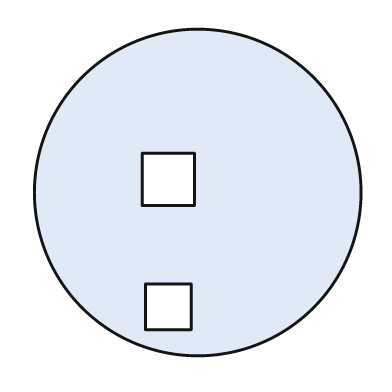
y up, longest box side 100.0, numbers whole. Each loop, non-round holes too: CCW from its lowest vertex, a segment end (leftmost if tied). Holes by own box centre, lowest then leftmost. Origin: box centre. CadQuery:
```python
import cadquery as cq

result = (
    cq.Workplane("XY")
    .moveTo(0.0, 0.0)
    .circle(50.0)
    .moveTo(-16.0, -42.0)
    .lineTo(-2.0, -42.0)
    .lineTo(-2.0, -28.0)
    .lineTo(-16.0, -28.0)
    .close()
    .moveTo(-17.0, -4.0)
    .lineTo(-1.0, -4.0)
    .lineTo(-1.0, 12.0)
    .lineTo(-17.0, 12.0)
    .close()
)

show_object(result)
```